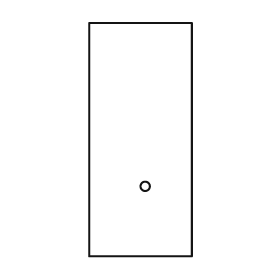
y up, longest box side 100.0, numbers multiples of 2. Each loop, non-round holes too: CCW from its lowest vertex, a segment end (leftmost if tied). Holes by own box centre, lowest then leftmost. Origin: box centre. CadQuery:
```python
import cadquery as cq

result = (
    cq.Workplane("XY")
    .moveTo(-22.0, -50.0)
    .lineTo(22.0, -50.0)
    .lineTo(22.0, 50.0)
    .lineTo(-22.0, 50.0)
    .close()
    .moveTo(2.0, -20.0)
    .circle(2.0)
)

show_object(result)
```